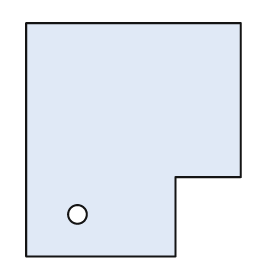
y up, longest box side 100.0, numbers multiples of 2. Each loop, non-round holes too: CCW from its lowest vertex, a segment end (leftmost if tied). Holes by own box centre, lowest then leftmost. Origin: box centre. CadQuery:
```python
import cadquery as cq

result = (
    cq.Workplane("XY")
    .moveTo(-46.0, -50.0)
    .lineTo(18.0, -50.0)
    .lineTo(18.0, -16.0)
    .lineTo(46.0, -16.0)
    .lineTo(46.0, 50.0)
    .lineTo(-46.0, 50.0)
    .close()
    .moveTo(-24.0, -32.0)
    .circle(4.0)
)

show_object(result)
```